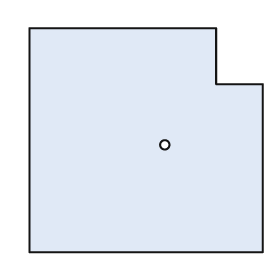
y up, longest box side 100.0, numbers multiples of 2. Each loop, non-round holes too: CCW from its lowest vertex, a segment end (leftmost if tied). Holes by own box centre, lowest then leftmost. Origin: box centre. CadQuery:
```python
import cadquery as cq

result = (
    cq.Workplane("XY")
    .moveTo(-50.0, -48.0)
    .lineTo(50.0, -48.0)
    .lineTo(50.0, 24.0)
    .lineTo(30.0, 24.0)
    .lineTo(30.0, 48.0)
    .lineTo(-50.0, 48.0)
    .close()
    .moveTo(8.0, -2.0)
    .circle(2.0)
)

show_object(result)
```